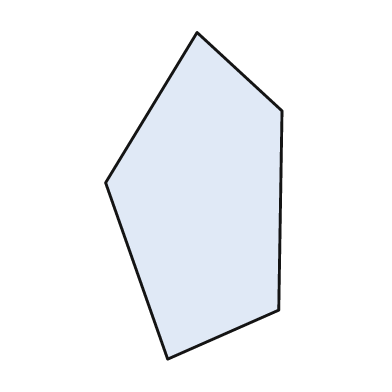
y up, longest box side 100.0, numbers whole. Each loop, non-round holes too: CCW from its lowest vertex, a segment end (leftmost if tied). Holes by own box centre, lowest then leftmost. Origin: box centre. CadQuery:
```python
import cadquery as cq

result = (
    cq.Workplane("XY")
    .moveTo(-8.0, -50.0)
    .lineTo(26.0, -35.0)
    .lineTo(27.0, 26.0)
    .lineTo(1.0, 50.0)
    .lineTo(-27.0, 4.0)
    .close()
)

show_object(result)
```